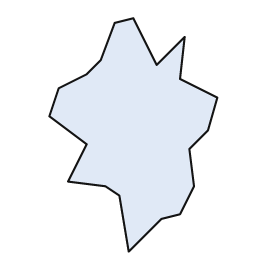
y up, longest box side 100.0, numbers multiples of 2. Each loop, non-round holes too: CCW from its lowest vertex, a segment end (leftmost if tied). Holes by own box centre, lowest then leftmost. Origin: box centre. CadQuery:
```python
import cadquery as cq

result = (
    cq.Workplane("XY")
    .moveTo(-2.0, -50.0)
    .lineTo(12.0, -36.0)
    .lineTo(20.0, -34.0)
    .lineTo(26.0, -22.0)
    .lineTo(24.0, -6.0)
    .lineTo(32.0, 2.0)
    .lineTo(36.0, 16.0)
    .lineTo(20.0, 24.0)
    .lineTo(22.0, 42.0)
    .lineTo(10.0, 30.0)
    .lineTo(0.0, 50.0)
    .lineTo(-8.0, 48.0)
    .lineTo(-14.0, 32.0)
    .lineTo(-20.0, 26.0)
    .lineTo(-32.0, 20.0)
    .lineTo(-36.0, 8.0)
    .lineTo(-20.0, -4.0)
    .lineTo(-28.0, -20.0)
    .lineTo(-12.0, -22.0)
    .lineTo(-6.0, -26.0)
    .close()
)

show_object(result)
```